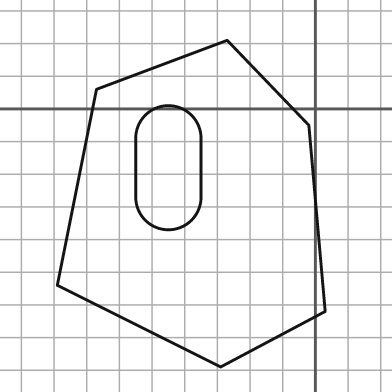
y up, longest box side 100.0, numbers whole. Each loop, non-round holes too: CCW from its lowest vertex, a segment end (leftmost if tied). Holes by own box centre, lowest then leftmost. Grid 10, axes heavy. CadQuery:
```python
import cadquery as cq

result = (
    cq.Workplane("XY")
    .moveTo(-29.0, -79.0)
    .lineTo(3.0, -62.0)
    .lineTo(-2.0, -5.0)
    .lineTo(-27.0, 21.0)
    .lineTo(-67.0, 6.0)
    .lineTo(-79.0, -54.0)
    .close()
    .moveTo(-55.0, -27.0)
    .threePointArc((-45.0, -37.0), (-35.0, -27.0))
    .lineTo(-35.0, -9.0)
    .threePointArc((-45.0, 1.0), (-55.0, -9.0))
    .close()
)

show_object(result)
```